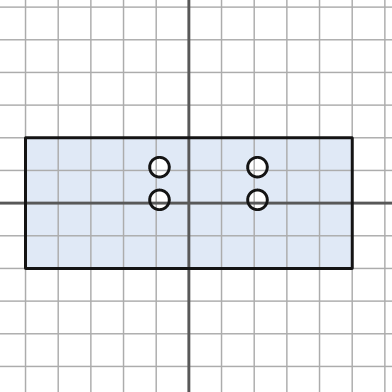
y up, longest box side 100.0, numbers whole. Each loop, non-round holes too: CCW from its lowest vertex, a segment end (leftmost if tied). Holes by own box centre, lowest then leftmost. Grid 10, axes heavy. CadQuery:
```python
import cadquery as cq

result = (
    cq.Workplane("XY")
    .moveTo(-50.0, -20.0)
    .lineTo(50.0, -20.0)
    .lineTo(50.0, 20.0)
    .lineTo(-50.0, 20.0)
    .close()
    .moveTo(-9.0, 1.0)
    .circle(3.0)
    .moveTo(21.0, 1.0)
    .circle(3.0)
    .moveTo(-9.0, 11.0)
    .circle(3.0)
    .moveTo(21.0, 11.0)
    .circle(3.0)
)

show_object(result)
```